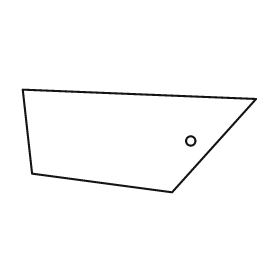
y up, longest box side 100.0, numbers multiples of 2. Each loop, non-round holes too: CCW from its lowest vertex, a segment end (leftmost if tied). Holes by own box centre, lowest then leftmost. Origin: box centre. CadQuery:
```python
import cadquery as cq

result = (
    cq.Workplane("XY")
    .moveTo(14.0, -22.0)
    .lineTo(50.0, 18.0)
    .lineTo(-50.0, 22.0)
    .lineTo(-46.0, -14.0)
    .close()
    .moveTo(22.0, 0.0)
    .circle(2.0)
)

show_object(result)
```